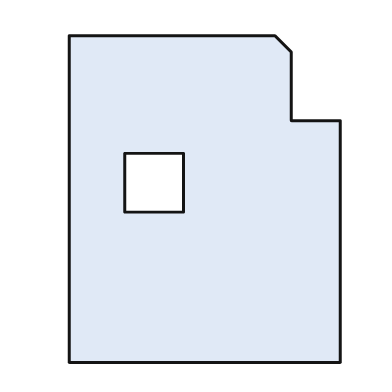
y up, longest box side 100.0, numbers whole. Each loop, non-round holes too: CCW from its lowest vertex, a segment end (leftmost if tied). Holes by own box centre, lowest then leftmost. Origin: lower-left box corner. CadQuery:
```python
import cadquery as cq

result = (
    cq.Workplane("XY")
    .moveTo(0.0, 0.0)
    .lineTo(83.0, 0.0)
    .lineTo(83.0, 74.0)
    .lineTo(68.0, 74.0)
    .lineTo(68.0, 95.0)
    .lineTo(63.0, 100.0)
    .lineTo(0.0, 100.0)
    .close()
    .moveTo(17.0, 46.0)
    .lineTo(35.0, 46.0)
    .lineTo(35.0, 64.0)
    .lineTo(17.0, 64.0)
    .close()
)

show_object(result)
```